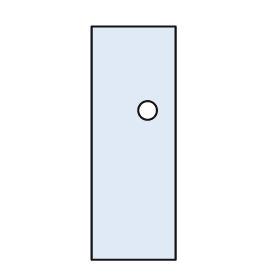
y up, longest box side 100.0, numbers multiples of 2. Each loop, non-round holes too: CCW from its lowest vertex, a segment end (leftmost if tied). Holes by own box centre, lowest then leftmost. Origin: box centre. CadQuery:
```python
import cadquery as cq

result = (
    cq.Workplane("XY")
    .moveTo(-18.0, -50.0)
    .lineTo(18.0, -50.0)
    .lineTo(18.0, 50.0)
    .lineTo(-18.0, 50.0)
    .close()
    .moveTo(6.0, 14.0)
    .circle(4.0)
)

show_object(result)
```